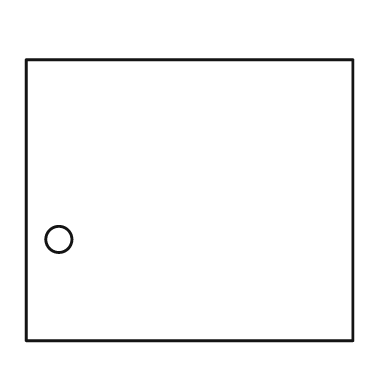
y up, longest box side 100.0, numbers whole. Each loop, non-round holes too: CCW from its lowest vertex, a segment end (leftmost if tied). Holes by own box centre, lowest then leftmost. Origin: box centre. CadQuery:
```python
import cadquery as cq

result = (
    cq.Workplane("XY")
    .moveTo(-50.0, -43.0)
    .lineTo(50.0, -43.0)
    .lineTo(50.0, 43.0)
    .lineTo(-50.0, 43.0)
    .close()
    .moveTo(-40.0, -12.0)
    .circle(4.0)
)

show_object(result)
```